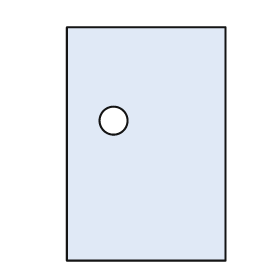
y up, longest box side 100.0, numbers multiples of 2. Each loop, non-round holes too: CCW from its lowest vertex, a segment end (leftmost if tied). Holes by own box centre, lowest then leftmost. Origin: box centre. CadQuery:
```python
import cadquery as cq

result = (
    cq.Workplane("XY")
    .moveTo(-34.0, -50.0)
    .lineTo(34.0, -50.0)
    .lineTo(34.0, 50.0)
    .lineTo(-34.0, 50.0)
    .close()
    .moveTo(-14.0, 10.0)
    .circle(6.0)
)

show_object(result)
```